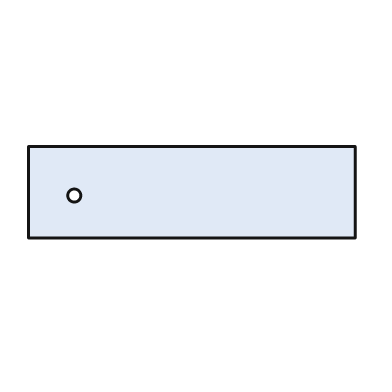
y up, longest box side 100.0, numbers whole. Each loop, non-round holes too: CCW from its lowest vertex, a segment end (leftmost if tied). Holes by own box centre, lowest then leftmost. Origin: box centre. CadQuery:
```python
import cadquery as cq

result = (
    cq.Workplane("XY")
    .moveTo(-50.0, -14.0)
    .lineTo(50.0, -14.0)
    .lineTo(50.0, 14.0)
    .lineTo(-50.0, 14.0)
    .close()
    .moveTo(-36.0, -1.0)
    .circle(2.0)
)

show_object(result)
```